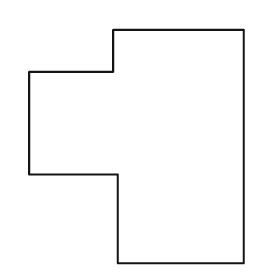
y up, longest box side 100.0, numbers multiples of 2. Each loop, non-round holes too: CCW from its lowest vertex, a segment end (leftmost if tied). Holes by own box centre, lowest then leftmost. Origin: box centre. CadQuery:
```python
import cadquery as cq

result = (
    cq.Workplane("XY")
    .moveTo(-8.0, -50.0)
    .lineTo(46.0, -50.0)
    .lineTo(46.0, 50.0)
    .lineTo(-10.0, 50.0)
    .lineTo(-10.0, 32.0)
    .lineTo(-46.0, 32.0)
    .lineTo(-46.0, -12.0)
    .lineTo(-8.0, -12.0)
    .close()
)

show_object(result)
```